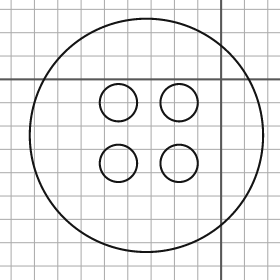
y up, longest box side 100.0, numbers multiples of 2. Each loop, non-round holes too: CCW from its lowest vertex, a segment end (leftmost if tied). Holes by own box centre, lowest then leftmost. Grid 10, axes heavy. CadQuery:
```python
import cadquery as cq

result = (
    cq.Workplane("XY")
    .moveTo(-32.0, -24.0)
    .circle(50.0)
    .moveTo(-44.0, -36.0)
    .circle(8.0)
    .moveTo(-18.0, -36.0)
    .circle(8.0)
    .moveTo(-44.0, -10.0)
    .circle(8.0)
    .moveTo(-18.0, -10.0)
    .circle(8.0)
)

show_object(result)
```